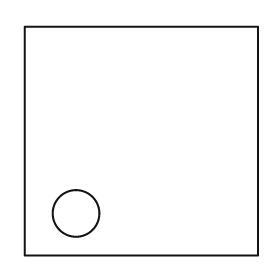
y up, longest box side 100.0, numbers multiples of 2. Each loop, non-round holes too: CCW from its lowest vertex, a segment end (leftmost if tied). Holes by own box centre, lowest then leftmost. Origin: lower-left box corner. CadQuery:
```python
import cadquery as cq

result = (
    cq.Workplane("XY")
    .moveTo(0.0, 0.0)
    .lineTo(100.0, 0.0)
    .lineTo(100.0, 98.0)
    .lineTo(0.0, 98.0)
    .close()
    .moveTo(22.0, 18.0)
    .circle(10.0)
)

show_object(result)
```